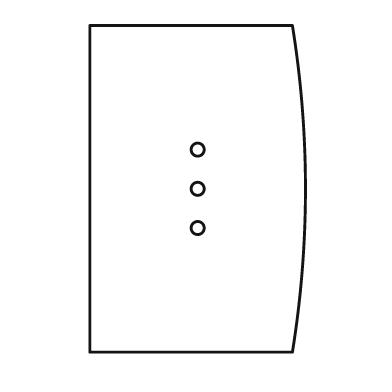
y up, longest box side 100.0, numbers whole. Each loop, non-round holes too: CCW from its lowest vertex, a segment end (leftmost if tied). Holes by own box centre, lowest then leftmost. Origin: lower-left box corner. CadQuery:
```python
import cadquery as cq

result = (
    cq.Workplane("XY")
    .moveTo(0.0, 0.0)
    .lineTo(62.0, 0.0)
    .threePointArc((66.0, 50.0), (62.0, 100.0))
    .lineTo(0.0, 100.0)
    .close()
    .moveTo(33.0, 38.0)
    .circle(2.0)
    .moveTo(33.0, 50.0)
    .circle(2.0)
    .moveTo(33.0, 62.0)
    .circle(2.0)
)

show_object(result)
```